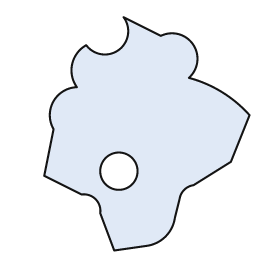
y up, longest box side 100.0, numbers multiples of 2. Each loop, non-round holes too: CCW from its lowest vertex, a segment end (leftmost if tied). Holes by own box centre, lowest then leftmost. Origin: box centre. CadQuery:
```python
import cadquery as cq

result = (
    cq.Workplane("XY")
    .moveTo(-14.0, -50.0)
    .lineTo(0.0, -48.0)
    .threePointArc((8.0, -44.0), (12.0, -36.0))
    .lineTo(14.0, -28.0)
    .threePointArc((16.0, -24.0), (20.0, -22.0))
    .lineTo(36.0, -12.0)
    .lineTo(44.0, 8.0)
    .threePointArc((32.0, 18.0), (18.0, 24.0))
    .threePointArc((20.0, 38.0), (6.0, 42.0))
    .lineTo(-10.0, 50.0)
    .threePointArc((-12.0, 36.0), (-26.0, 38.0))
    .threePointArc((-32.0, 30.0), (-30.0, 20.0))
    .threePointArc((-40.0, 14.0), (-40.0, 2.0))
    .lineTo(-44.0, -18.0)
    .lineTo(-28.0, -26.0)
    .threePointArc((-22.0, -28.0), (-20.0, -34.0))
    .close()
    .moveTo(-12.0, -16.0)
    .circle(8.0)
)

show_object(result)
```